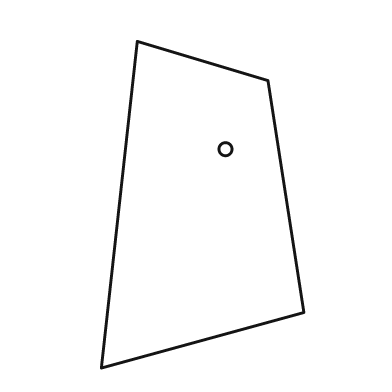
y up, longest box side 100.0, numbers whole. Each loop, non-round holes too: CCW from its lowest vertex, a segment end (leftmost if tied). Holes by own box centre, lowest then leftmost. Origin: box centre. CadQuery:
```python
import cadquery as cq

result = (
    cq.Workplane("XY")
    .moveTo(-31.0, -50.0)
    .lineTo(31.0, -33.0)
    .lineTo(20.0, 38.0)
    .lineTo(-20.0, 50.0)
    .close()
    .moveTo(7.0, 17.0)
    .circle(2.0)
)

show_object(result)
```